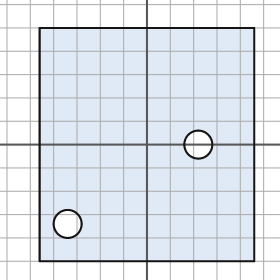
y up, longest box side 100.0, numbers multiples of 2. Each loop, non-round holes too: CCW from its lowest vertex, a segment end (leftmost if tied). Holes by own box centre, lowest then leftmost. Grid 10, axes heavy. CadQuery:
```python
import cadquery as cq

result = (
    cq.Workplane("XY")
    .moveTo(-46.0, -50.0)
    .lineTo(46.0, -50.0)
    .lineTo(46.0, 50.0)
    .lineTo(-46.0, 50.0)
    .close()
    .moveTo(-34.0, -34.0)
    .circle(6.0)
    .moveTo(22.0, 0.0)
    .circle(6.0)
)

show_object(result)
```